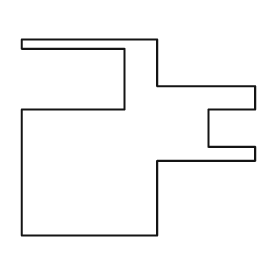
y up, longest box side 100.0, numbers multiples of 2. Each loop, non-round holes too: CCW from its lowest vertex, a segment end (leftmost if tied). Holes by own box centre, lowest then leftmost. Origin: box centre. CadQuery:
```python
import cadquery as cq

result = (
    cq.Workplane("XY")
    .moveTo(-50.0, -42.0)
    .lineTo(8.0, -42.0)
    .lineTo(8.0, -10.0)
    .lineTo(50.0, -10.0)
    .lineTo(50.0, -4.0)
    .lineTo(30.0, -4.0)
    .lineTo(30.0, 12.0)
    .lineTo(50.0, 12.0)
    .lineTo(50.0, 22.0)
    .lineTo(8.0, 22.0)
    .lineTo(8.0, 42.0)
    .lineTo(-50.0, 42.0)
    .lineTo(-50.0, 38.0)
    .lineTo(-6.0, 38.0)
    .lineTo(-6.0, 12.0)
    .lineTo(-50.0, 12.0)
    .close()
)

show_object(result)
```